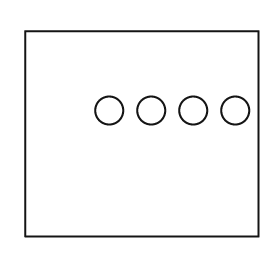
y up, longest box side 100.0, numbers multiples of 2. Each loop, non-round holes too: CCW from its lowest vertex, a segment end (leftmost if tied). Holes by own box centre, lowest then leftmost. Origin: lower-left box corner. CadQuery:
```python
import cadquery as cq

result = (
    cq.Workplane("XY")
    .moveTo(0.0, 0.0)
    .lineTo(100.0, 0.0)
    .lineTo(100.0, 88.0)
    .lineTo(0.0, 88.0)
    .close()
    .moveTo(36.0, 54.0)
    .circle(6.0)
    .moveTo(54.0, 54.0)
    .circle(6.0)
    .moveTo(72.0, 54.0)
    .circle(6.0)
    .moveTo(90.0, 54.0)
    .circle(6.0)
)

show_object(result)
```